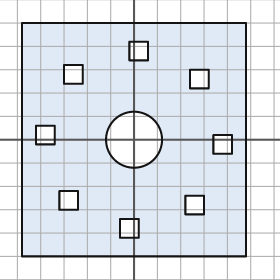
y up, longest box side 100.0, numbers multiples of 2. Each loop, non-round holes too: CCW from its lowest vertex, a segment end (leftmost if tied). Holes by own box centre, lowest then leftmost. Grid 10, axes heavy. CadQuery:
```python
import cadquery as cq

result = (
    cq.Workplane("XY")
    .moveTo(-48.0, -50.0)
    .lineTo(48.0, -50.0)
    .lineTo(48.0, 50.0)
    .lineTo(-48.0, 50.0)
    .close()
    .moveTo(-6.0, -42.0)
    .lineTo(2.0, -42.0)
    .lineTo(2.0, -34.0)
    .lineTo(-6.0, -34.0)
    .close()
    .moveTo(22.0, -32.0)
    .lineTo(30.0, -32.0)
    .lineTo(30.0, -24.0)
    .lineTo(22.0, -24.0)
    .close()
    .moveTo(-32.0, -30.0)
    .lineTo(-24.0, -30.0)
    .lineTo(-24.0, -22.0)
    .lineTo(-32.0, -22.0)
    .close()
    .moveTo(34.0, -6.0)
    .lineTo(42.0, -6.0)
    .lineTo(42.0, 2.0)
    .lineTo(34.0, 2.0)
    .close()
    .moveTo(0.0, 0.0)
    .circle(12.0)
    .moveTo(-42.0, -2.0)
    .lineTo(-34.0, -2.0)
    .lineTo(-34.0, 6.0)
    .lineTo(-42.0, 6.0)
    .close()
    .moveTo(24.0, 22.0)
    .lineTo(32.0, 22.0)
    .lineTo(32.0, 30.0)
    .lineTo(24.0, 30.0)
    .close()
    .moveTo(-30.0, 24.0)
    .lineTo(-22.0, 24.0)
    .lineTo(-22.0, 32.0)
    .lineTo(-30.0, 32.0)
    .close()
    .moveTo(-2.0, 34.0)
    .lineTo(6.0, 34.0)
    .lineTo(6.0, 42.0)
    .lineTo(-2.0, 42.0)
    .close()
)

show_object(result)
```